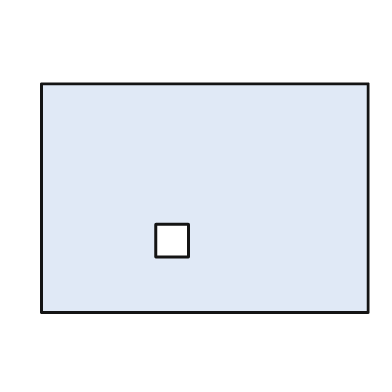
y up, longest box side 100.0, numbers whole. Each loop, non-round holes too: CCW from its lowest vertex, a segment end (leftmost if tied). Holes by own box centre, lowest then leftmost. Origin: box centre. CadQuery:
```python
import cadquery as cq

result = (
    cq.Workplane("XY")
    .moveTo(-50.0, -35.0)
    .lineTo(50.0, -35.0)
    .lineTo(50.0, 35.0)
    .lineTo(-50.0, 35.0)
    .close()
    .moveTo(-15.0, -18.0)
    .lineTo(-5.0, -18.0)
    .lineTo(-5.0, -8.0)
    .lineTo(-15.0, -8.0)
    .close()
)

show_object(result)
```